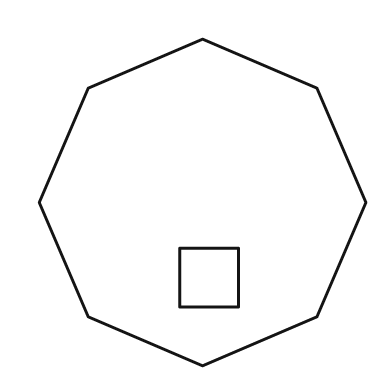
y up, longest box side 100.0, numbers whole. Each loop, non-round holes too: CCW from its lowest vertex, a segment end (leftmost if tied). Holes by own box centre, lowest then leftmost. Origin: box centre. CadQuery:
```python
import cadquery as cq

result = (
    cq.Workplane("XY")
    .moveTo(0.0, -50.0)
    .lineTo(35.0, -35.0)
    .lineTo(50.0, 0.0)
    .lineTo(35.0, 35.0)
    .lineTo(0.0, 50.0)
    .lineTo(-35.0, 35.0)
    .lineTo(-50.0, 0.0)
    .lineTo(-35.0, -35.0)
    .close()
    .moveTo(-7.0, -32.0)
    .lineTo(11.0, -32.0)
    .lineTo(11.0, -14.0)
    .lineTo(-7.0, -14.0)
    .close()
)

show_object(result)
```